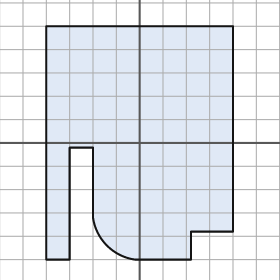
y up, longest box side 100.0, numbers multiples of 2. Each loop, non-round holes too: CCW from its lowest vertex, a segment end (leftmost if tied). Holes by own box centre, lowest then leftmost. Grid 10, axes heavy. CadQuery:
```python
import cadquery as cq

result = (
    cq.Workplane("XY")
    .moveTo(-40.0, -50.0)
    .lineTo(-30.0, -50.0)
    .lineTo(-30.0, -2.0)
    .lineTo(-20.0, -2.0)
    .lineTo(-20.0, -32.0)
    .threePointArc((-14.0, -44.0), (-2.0, -50.0))
    .lineTo(22.0, -50.0)
    .lineTo(22.0, -38.0)
    .lineTo(40.0, -38.0)
    .lineTo(40.0, 50.0)
    .lineTo(-40.0, 50.0)
    .close()
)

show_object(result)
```